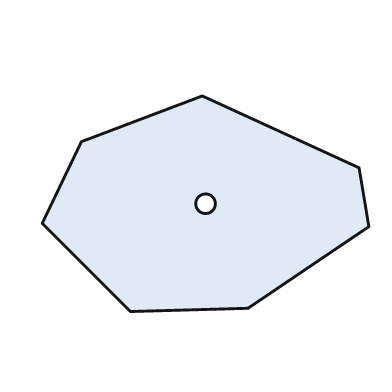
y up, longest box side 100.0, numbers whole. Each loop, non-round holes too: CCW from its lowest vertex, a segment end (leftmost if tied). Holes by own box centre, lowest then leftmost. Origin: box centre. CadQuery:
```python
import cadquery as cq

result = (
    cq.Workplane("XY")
    .moveTo(-23.0, -33.0)
    .lineTo(13.0, -32.0)
    .lineTo(50.0, -7.0)
    .lineTo(47.0, 11.0)
    .lineTo(-1.0, 33.0)
    .lineTo(-38.0, 19.0)
    .lineTo(-50.0, -6.0)
    .close()
    .moveTo(0.0, 0.0)
    .circle(3.0)
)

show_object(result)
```